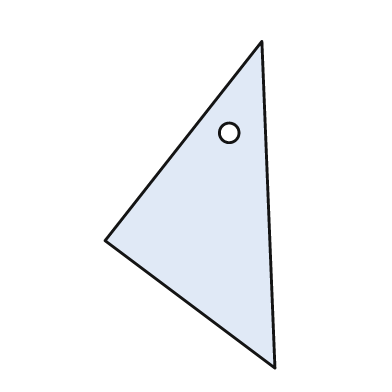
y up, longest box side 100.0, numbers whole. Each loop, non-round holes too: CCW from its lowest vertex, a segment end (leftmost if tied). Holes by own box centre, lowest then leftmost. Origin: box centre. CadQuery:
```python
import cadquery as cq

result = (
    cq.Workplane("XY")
    .moveTo(26.0, -50.0)
    .lineTo(22.0, 50.0)
    .lineTo(-26.0, -11.0)
    .close()
    .moveTo(12.0, 22.0)
    .circle(3.0)
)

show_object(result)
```